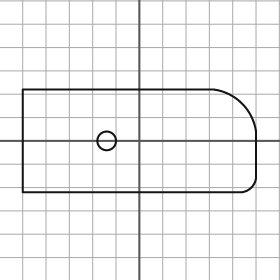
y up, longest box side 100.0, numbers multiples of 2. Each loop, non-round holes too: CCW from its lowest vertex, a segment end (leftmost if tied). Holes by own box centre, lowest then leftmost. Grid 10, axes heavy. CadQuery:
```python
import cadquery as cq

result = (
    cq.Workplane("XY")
    .moveTo(-50.0, -22.0)
    .lineTo(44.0, -22.0)
    .threePointArc((48.0, -20.0), (50.0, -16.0))
    .lineTo(50.0, 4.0)
    .threePointArc((44.0, 16.0), (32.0, 22.0))
    .lineTo(-50.0, 22.0)
    .close()
    .moveTo(-14.0, 0.0)
    .circle(4.0)
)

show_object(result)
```